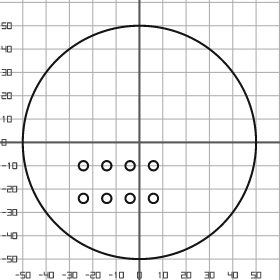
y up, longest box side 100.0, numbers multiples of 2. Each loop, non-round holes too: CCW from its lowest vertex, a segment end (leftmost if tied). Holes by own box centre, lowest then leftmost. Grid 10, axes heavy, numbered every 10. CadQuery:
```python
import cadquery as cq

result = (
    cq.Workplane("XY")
    .moveTo(0.0, 0.0)
    .circle(50.0)
    .moveTo(-24.0, -24.0)
    .circle(2.0)
    .moveTo(-14.0, -24.0)
    .circle(2.0)
    .moveTo(-4.0, -24.0)
    .circle(2.0)
    .moveTo(6.0, -24.0)
    .circle(2.0)
    .moveTo(-24.0, -10.0)
    .circle(2.0)
    .moveTo(-14.0, -10.0)
    .circle(2.0)
    .moveTo(-4.0, -10.0)
    .circle(2.0)
    .moveTo(6.0, -10.0)
    .circle(2.0)
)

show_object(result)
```